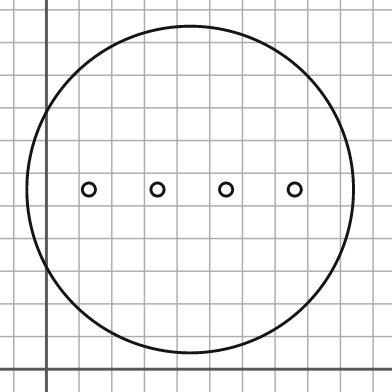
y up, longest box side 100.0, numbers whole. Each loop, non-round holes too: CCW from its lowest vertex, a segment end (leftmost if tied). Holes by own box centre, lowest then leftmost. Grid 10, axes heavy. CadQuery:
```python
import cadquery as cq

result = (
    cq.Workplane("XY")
    .moveTo(44.0, 55.0)
    .circle(50.0)
    .moveTo(13.0, 55.0)
    .circle(2.0)
    .moveTo(34.0, 55.0)
    .circle(2.0)
    .moveTo(55.0, 55.0)
    .circle(2.0)
    .moveTo(76.0, 55.0)
    .circle(2.0)
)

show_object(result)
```